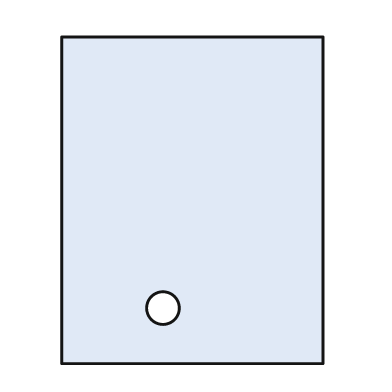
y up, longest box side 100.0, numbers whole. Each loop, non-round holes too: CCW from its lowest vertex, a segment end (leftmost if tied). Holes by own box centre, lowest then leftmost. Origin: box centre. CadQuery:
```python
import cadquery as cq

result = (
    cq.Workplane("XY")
    .moveTo(-40.0, -50.0)
    .lineTo(40.0, -50.0)
    .lineTo(40.0, 50.0)
    .lineTo(-40.0, 50.0)
    .close()
    .moveTo(-9.0, -33.0)
    .circle(5.0)
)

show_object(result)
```